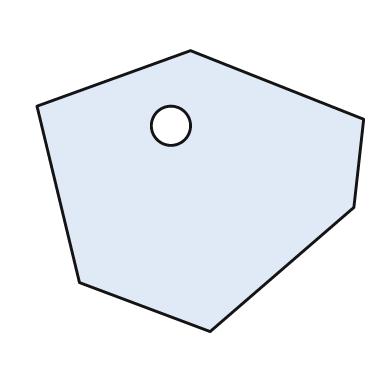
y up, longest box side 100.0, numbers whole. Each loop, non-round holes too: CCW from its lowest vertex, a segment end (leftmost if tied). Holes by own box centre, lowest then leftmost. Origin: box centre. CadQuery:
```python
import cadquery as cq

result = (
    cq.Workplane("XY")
    .moveTo(3.0, -43.0)
    .lineTo(47.0, -5.0)
    .lineTo(50.0, 22.0)
    .lineTo(-3.0, 43.0)
    .lineTo(-50.0, 26.0)
    .lineTo(-37.0, -28.0)
    .close()
    .moveTo(-9.0, 20.0)
    .circle(6.0)
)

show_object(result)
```